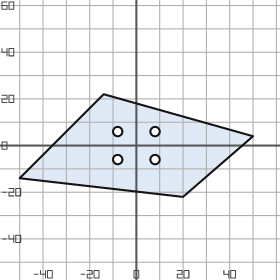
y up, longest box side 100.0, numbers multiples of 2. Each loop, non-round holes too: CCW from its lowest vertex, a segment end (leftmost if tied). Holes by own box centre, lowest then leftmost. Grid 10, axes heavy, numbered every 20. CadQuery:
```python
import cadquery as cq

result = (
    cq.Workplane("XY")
    .moveTo(20.0, -22.0)
    .lineTo(50.0, 4.0)
    .lineTo(-14.0, 22.0)
    .lineTo(-50.0, -14.0)
    .close()
    .moveTo(-8.0, -6.0)
    .circle(2.0)
    .moveTo(8.0, -6.0)
    .circle(2.0)
    .moveTo(-8.0, 6.0)
    .circle(2.0)
    .moveTo(8.0, 6.0)
    .circle(2.0)
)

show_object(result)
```